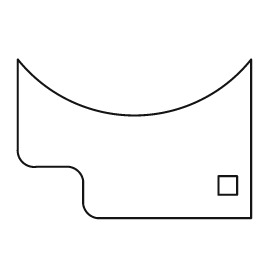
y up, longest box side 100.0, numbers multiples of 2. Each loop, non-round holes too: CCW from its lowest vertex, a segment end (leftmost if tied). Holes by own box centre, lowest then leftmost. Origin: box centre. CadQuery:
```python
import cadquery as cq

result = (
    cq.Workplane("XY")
    .moveTo(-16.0, -34.0)
    .lineTo(50.0, -34.0)
    .lineTo(50.0, 34.0)
    .threePointArc((0.0, 10.0), (-50.0, 34.0))
    .lineTo(-50.0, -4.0)
    .threePointArc((-48.0, -10.0), (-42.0, -12.0))
    .lineTo(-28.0, -12.0)
    .threePointArc((-24.0, -14.0), (-22.0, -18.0))
    .lineTo(-22.0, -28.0)
    .threePointArc((-20.0, -32.0), (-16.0, -34.0))
    .close()
    .moveTo(36.0, -24.0)
    .lineTo(44.0, -24.0)
    .lineTo(44.0, -16.0)
    .lineTo(36.0, -16.0)
    .close()
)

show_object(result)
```